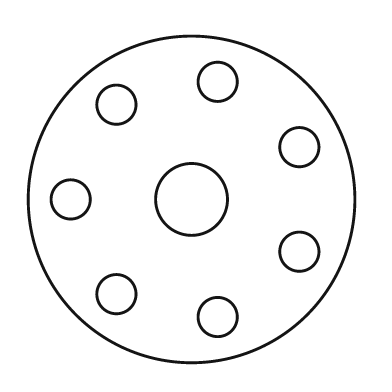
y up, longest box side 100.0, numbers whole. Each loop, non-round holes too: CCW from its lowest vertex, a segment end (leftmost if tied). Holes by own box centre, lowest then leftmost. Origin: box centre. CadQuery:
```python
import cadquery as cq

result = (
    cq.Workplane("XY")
    .moveTo(0.0, 0.0)
    .circle(50.0)
    .moveTo(8.0, -36.0)
    .circle(6.0)
    .moveTo(-23.0, -29.0)
    .circle(6.0)
    .moveTo(33.0, -16.0)
    .circle(6.0)
    .moveTo(-37.0, 0.0)
    .circle(6.0)
    .moveTo(0.0, 0.0)
    .circle(11.0)
    .moveTo(33.0, 16.0)
    .circle(6.0)
    .moveTo(-23.0, 29.0)
    .circle(6.0)
    .moveTo(8.0, 36.0)
    .circle(6.0)
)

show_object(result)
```